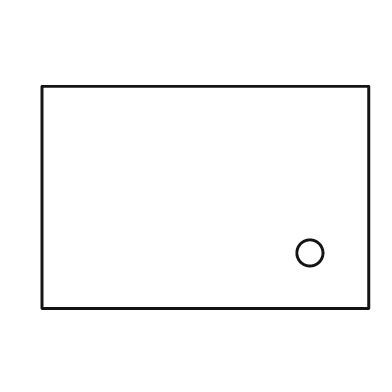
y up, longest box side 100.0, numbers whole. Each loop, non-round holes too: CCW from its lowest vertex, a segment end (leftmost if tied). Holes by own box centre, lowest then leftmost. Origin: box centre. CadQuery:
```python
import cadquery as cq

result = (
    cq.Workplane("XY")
    .moveTo(-50.0, -34.0)
    .lineTo(50.0, -34.0)
    .lineTo(50.0, 34.0)
    .lineTo(-50.0, 34.0)
    .close()
    .moveTo(32.0, -17.0)
    .circle(4.0)
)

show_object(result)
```